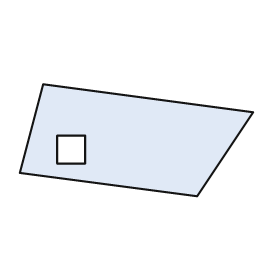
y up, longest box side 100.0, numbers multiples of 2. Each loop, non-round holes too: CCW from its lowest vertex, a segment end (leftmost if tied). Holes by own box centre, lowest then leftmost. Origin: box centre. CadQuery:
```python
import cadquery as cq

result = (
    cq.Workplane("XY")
    .moveTo(26.0, -24.0)
    .lineTo(50.0, 12.0)
    .lineTo(-40.0, 24.0)
    .lineTo(-50.0, -14.0)
    .close()
    .moveTo(-34.0, -10.0)
    .lineTo(-22.0, -10.0)
    .lineTo(-22.0, 2.0)
    .lineTo(-34.0, 2.0)
    .close()
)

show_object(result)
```